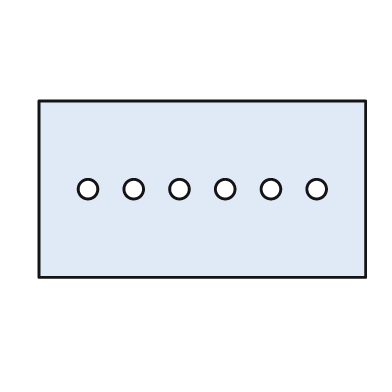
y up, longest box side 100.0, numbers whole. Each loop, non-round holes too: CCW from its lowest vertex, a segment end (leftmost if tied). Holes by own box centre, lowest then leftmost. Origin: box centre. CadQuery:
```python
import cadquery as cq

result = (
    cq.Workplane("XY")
    .moveTo(-50.0, -27.0)
    .lineTo(50.0, -27.0)
    .lineTo(50.0, 27.0)
    .lineTo(-50.0, 27.0)
    .close()
    .moveTo(-35.0, 0.0)
    .circle(3.0)
    .moveTo(-21.0, 0.0)
    .circle(3.0)
    .moveTo(-7.0, 0.0)
    .circle(3.0)
    .moveTo(7.0, 0.0)
    .circle(3.0)
    .moveTo(21.0, 0.0)
    .circle(3.0)
    .moveTo(35.0, 0.0)
    .circle(3.0)
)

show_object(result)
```